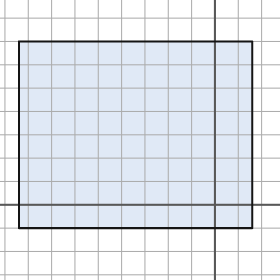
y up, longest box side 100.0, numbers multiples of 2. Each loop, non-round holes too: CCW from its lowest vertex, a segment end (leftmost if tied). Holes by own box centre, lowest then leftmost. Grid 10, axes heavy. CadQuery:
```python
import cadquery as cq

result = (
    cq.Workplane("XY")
    .moveTo(-84.0, -10.0)
    .lineTo(16.0, -10.0)
    .lineTo(16.0, 70.0)
    .lineTo(-84.0, 70.0)
    .close()
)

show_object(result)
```